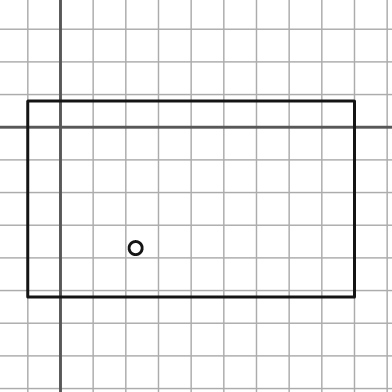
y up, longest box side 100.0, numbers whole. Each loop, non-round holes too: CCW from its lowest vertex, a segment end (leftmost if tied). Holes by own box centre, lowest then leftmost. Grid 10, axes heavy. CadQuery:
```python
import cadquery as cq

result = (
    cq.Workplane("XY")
    .moveTo(-10.0, -52.0)
    .lineTo(90.0, -52.0)
    .lineTo(90.0, 8.0)
    .lineTo(-10.0, 8.0)
    .close()
    .moveTo(23.0, -37.0)
    .circle(2.0)
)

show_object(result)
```